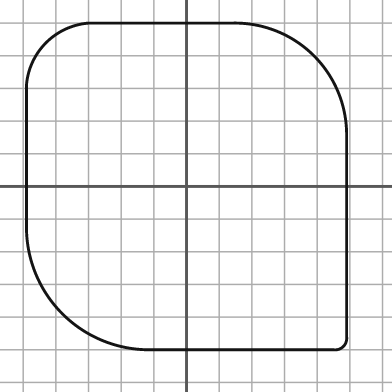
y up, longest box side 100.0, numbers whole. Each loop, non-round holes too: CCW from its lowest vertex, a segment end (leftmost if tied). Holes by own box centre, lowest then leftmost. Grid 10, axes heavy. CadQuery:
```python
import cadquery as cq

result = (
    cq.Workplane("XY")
    .moveTo(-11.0, -50.0)
    .lineTo(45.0, -50.0)
    .threePointArc((48.0, -49.0), (49.0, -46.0))
    .lineTo(49.0, 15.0)
    .threePointArc((39.0, 40.0), (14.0, 50.0))
    .lineTo(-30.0, 50.0)
    .threePointArc((-43.0, 44.0), (-49.0, 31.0))
    .lineTo(-49.0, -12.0)
    .threePointArc((-38.0, -39.0), (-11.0, -50.0))
    .close()
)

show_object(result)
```